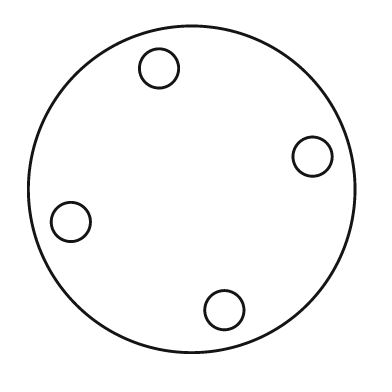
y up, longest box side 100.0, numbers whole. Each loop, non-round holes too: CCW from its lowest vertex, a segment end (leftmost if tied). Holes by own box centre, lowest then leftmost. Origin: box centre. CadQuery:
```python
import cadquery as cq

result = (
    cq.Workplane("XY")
    .moveTo(0.0, 0.0)
    .circle(50.0)
    .moveTo(10.0, -37.0)
    .circle(6.0)
    .moveTo(-37.0, -10.0)
    .circle(6.0)
    .moveTo(37.0, 10.0)
    .circle(6.0)
    .moveTo(-10.0, 37.0)
    .circle(6.0)
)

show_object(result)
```